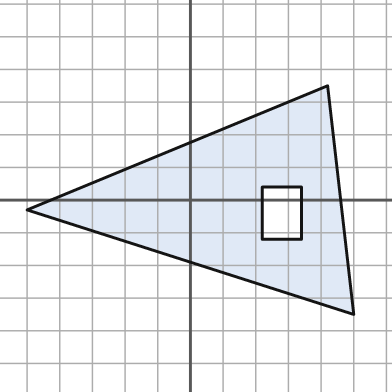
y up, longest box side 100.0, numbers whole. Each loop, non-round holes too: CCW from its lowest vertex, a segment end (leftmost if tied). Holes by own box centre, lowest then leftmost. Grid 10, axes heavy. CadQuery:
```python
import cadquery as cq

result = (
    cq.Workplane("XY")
    .moveTo(50.0, -35.0)
    .lineTo(42.0, 35.0)
    .lineTo(-50.0, -3.0)
    .close()
    .moveTo(22.0, -12.0)
    .lineTo(34.0, -12.0)
    .lineTo(34.0, 4.0)
    .lineTo(22.0, 4.0)
    .close()
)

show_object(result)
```